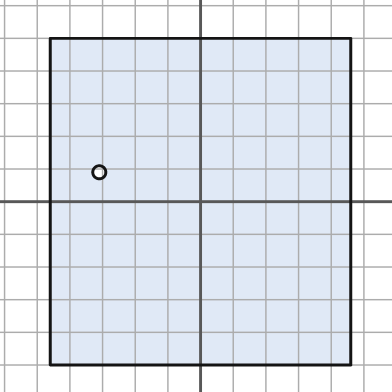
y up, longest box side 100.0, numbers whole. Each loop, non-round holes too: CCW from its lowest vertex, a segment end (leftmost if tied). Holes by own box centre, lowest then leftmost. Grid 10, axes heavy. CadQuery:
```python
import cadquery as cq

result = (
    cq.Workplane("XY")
    .moveTo(-46.0, -50.0)
    .lineTo(46.0, -50.0)
    .lineTo(46.0, 50.0)
    .lineTo(-46.0, 50.0)
    .close()
    .moveTo(-31.0, 9.0)
    .circle(2.0)
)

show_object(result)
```